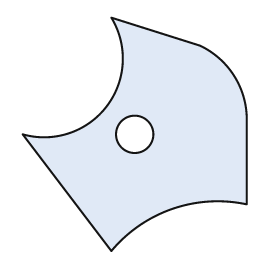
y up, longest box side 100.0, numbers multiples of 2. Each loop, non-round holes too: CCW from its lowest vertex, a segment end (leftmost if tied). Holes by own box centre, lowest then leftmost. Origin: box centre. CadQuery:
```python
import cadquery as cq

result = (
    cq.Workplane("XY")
    .moveTo(-10.0, -50.0)
    .threePointArc((16.0, -32.0), (48.0, -30.0))
    .lineTo(48.0, 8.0)
    .threePointArc((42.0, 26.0), (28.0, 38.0))
    .lineTo(-10.0, 50.0)
    .threePointArc((-12.0, 12.0), (-48.0, 0.0))
    .close()
    .moveTo(0.0, 0.0)
    .circle(8.0)
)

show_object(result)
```